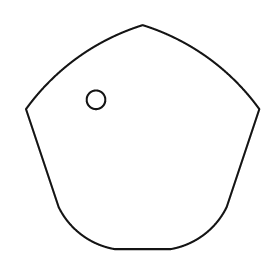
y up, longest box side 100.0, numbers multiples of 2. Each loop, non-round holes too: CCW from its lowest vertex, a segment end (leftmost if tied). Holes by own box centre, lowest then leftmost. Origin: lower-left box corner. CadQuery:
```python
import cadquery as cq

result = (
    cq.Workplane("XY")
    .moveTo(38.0, 0.0)
    .lineTo(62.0, 0.0)
    .threePointArc((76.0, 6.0), (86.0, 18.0))
    .lineTo(100.0, 60.0)
    .threePointArc((78.0, 82.0), (50.0, 96.0))
    .threePointArc((22.0, 82.0), (0.0, 60.0))
    .lineTo(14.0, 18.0)
    .threePointArc((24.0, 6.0), (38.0, 0.0))
    .close()
    .moveTo(30.0, 64.0)
    .circle(4.0)
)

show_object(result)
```